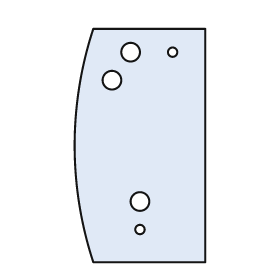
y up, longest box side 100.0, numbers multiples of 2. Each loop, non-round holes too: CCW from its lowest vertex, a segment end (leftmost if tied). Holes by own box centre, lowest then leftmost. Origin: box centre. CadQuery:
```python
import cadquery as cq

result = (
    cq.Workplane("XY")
    .moveTo(-20.0, -50.0)
    .lineTo(28.0, -50.0)
    .lineTo(28.0, 50.0)
    .lineTo(-20.0, 50.0)
    .threePointArc((-28.0, 0.0), (-20.0, -50.0))
    .close()
    .moveTo(0.0, -36.0)
    .circle(2.0)
    .moveTo(0.0, -24.0)
    .circle(4.0)
    .moveTo(-12.0, 28.0)
    .circle(4.0)
    .moveTo(-4.0, 40.0)
    .circle(4.0)
    .moveTo(14.0, 40.0)
    .circle(2.0)
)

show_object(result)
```